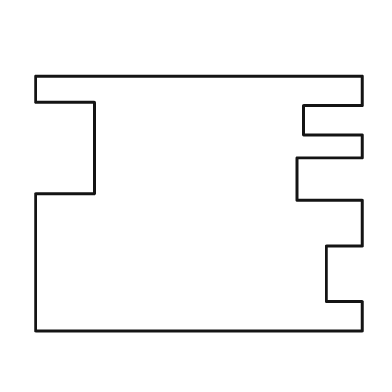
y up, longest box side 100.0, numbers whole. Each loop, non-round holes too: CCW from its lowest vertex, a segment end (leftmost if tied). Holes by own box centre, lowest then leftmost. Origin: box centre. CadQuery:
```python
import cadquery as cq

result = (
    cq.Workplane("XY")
    .moveTo(-50.0, -39.0)
    .lineTo(50.0, -39.0)
    .lineTo(50.0, -30.0)
    .lineTo(39.0, -30.0)
    .lineTo(39.0, -13.0)
    .lineTo(50.0, -13.0)
    .lineTo(50.0, 1.0)
    .lineTo(30.0, 1.0)
    .lineTo(30.0, 14.0)
    .lineTo(50.0, 14.0)
    .lineTo(50.0, 21.0)
    .lineTo(32.0, 21.0)
    .lineTo(32.0, 30.0)
    .lineTo(50.0, 30.0)
    .lineTo(50.0, 39.0)
    .lineTo(-50.0, 39.0)
    .lineTo(-50.0, 31.0)
    .lineTo(-32.0, 31.0)
    .lineTo(-32.0, 3.0)
    .lineTo(-50.0, 3.0)
    .close()
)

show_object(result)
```